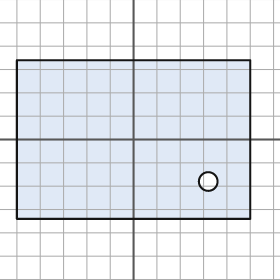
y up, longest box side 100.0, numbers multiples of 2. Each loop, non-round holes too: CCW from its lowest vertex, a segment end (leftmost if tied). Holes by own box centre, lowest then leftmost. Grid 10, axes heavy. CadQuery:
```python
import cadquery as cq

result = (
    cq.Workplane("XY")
    .moveTo(-50.0, -34.0)
    .lineTo(50.0, -34.0)
    .lineTo(50.0, 34.0)
    .lineTo(-50.0, 34.0)
    .close()
    .moveTo(32.0, -18.0)
    .circle(4.0)
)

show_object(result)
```